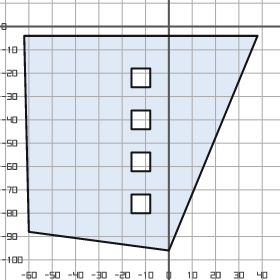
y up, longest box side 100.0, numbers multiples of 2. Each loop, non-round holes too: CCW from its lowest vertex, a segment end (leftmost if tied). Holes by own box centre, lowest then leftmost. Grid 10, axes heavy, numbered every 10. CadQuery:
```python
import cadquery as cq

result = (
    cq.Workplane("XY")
    .moveTo(0.0, -96.0)
    .lineTo(38.0, -4.0)
    .lineTo(-62.0, -4.0)
    .lineTo(-60.0, -88.0)
    .close()
    .moveTo(-16.0, -80.0)
    .lineTo(-8.0, -80.0)
    .lineTo(-8.0, -72.0)
    .lineTo(-16.0, -72.0)
    .close()
    .moveTo(-16.0, -62.0)
    .lineTo(-8.0, -62.0)
    .lineTo(-8.0, -54.0)
    .lineTo(-16.0, -54.0)
    .close()
    .moveTo(-16.0, -44.0)
    .lineTo(-8.0, -44.0)
    .lineTo(-8.0, -36.0)
    .lineTo(-16.0, -36.0)
    .close()
    .moveTo(-16.0, -26.0)
    .lineTo(-8.0, -26.0)
    .lineTo(-8.0, -18.0)
    .lineTo(-16.0, -18.0)
    .close()
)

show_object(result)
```